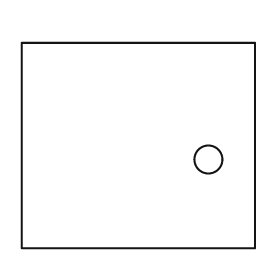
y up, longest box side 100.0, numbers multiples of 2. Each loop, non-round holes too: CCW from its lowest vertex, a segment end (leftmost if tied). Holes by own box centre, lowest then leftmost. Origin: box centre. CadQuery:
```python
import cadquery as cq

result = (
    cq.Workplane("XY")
    .moveTo(-50.0, -44.0)
    .lineTo(50.0, -44.0)
    .lineTo(50.0, 44.0)
    .lineTo(-50.0, 44.0)
    .close()
    .moveTo(30.0, -6.0)
    .circle(6.0)
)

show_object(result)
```